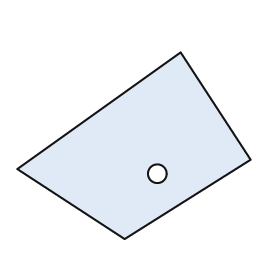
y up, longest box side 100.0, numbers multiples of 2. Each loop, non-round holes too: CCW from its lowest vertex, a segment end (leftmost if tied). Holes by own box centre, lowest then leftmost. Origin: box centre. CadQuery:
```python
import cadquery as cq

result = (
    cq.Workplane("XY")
    .moveTo(-4.0, -40.0)
    .lineTo(50.0, -6.0)
    .lineTo(20.0, 40.0)
    .lineTo(-50.0, -10.0)
    .close()
    .moveTo(10.0, -12.0)
    .circle(4.0)
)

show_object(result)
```